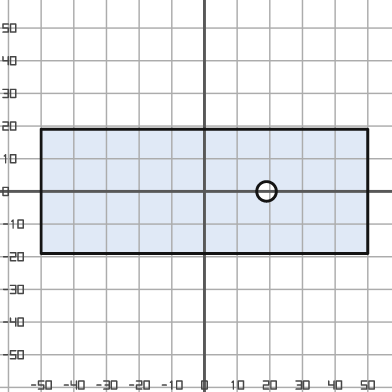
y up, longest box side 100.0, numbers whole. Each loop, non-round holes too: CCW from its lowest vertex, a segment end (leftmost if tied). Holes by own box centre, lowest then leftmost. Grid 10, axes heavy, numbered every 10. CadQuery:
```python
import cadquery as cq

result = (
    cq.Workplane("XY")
    .moveTo(-50.0, -19.0)
    .lineTo(50.0, -19.0)
    .lineTo(50.0, 19.0)
    .lineTo(-50.0, 19.0)
    .close()
    .moveTo(19.0, 0.0)
    .circle(3.0)
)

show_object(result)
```